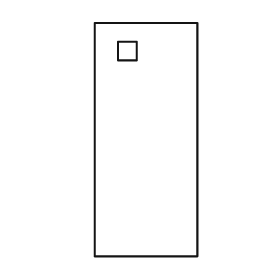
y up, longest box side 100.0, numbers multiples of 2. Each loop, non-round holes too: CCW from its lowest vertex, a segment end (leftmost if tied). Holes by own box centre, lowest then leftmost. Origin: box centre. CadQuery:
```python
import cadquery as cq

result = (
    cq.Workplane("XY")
    .moveTo(-22.0, -50.0)
    .lineTo(22.0, -50.0)
    .lineTo(22.0, 50.0)
    .lineTo(-22.0, 50.0)
    .close()
    .moveTo(-12.0, 34.0)
    .lineTo(-4.0, 34.0)
    .lineTo(-4.0, 42.0)
    .lineTo(-12.0, 42.0)
    .close()
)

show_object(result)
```